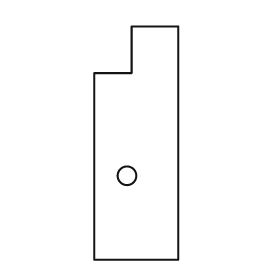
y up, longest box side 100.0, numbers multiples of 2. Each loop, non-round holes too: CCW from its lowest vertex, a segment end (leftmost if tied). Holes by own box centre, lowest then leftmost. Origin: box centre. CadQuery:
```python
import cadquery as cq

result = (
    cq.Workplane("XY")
    .moveTo(-18.0, -50.0)
    .lineTo(18.0, -50.0)
    .lineTo(18.0, 50.0)
    .lineTo(-2.0, 50.0)
    .lineTo(-2.0, 30.0)
    .lineTo(-18.0, 30.0)
    .close()
    .moveTo(-4.0, -14.0)
    .circle(4.0)
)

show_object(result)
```